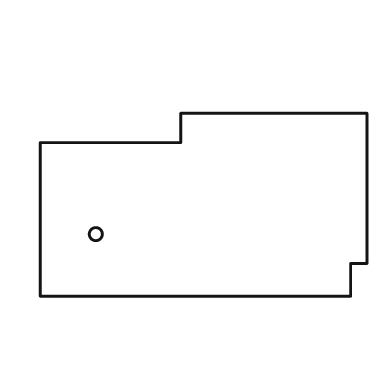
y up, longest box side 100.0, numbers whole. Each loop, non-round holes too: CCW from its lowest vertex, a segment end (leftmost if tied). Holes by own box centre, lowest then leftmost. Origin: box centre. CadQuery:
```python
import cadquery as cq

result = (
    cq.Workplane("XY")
    .moveTo(-50.0, -28.0)
    .lineTo(45.0, -28.0)
    .lineTo(45.0, -18.0)
    .lineTo(50.0, -18.0)
    .lineTo(50.0, 28.0)
    .lineTo(-7.0, 28.0)
    .lineTo(-7.0, 19.0)
    .lineTo(-50.0, 19.0)
    .close()
    .moveTo(-33.0, -9.0)
    .circle(2.0)
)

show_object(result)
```